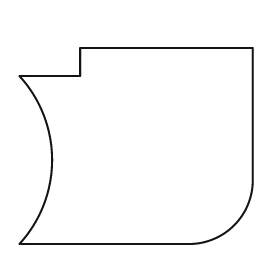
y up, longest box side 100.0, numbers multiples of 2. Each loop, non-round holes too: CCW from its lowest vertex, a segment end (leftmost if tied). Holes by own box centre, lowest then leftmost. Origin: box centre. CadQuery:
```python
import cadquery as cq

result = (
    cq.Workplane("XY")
    .moveTo(-50.0, -42.0)
    .lineTo(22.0, -42.0)
    .threePointArc((42.0, -34.0), (50.0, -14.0))
    .lineTo(50.0, 42.0)
    .lineTo(-24.0, 42.0)
    .lineTo(-24.0, 30.0)
    .lineTo(-50.0, 30.0)
    .threePointArc((-36.0, -6.0), (-50.0, -42.0))
    .close()
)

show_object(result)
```